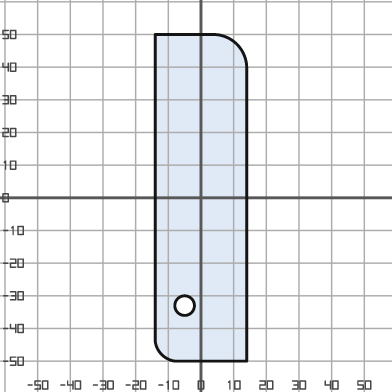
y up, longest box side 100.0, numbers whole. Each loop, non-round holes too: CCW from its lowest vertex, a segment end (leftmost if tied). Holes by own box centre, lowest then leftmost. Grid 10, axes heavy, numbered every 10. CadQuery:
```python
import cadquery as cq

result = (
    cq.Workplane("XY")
    .moveTo(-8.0, -50.0)
    .lineTo(14.0, -50.0)
    .lineTo(14.0, 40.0)
    .threePointArc((11.0, 47.0), (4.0, 50.0))
    .lineTo(-14.0, 50.0)
    .lineTo(-14.0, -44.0)
    .threePointArc((-12.0, -48.0), (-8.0, -50.0))
    .close()
    .moveTo(-5.0, -33.0)
    .circle(3.0)
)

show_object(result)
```